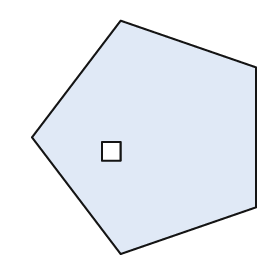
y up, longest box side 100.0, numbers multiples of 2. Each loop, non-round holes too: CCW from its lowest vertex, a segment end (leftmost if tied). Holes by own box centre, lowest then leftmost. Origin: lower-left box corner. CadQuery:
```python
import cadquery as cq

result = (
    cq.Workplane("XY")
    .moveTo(38.0, 0.0)
    .lineTo(96.0, 20.0)
    .lineTo(96.0, 80.0)
    .lineTo(38.0, 100.0)
    .lineTo(0.0, 50.0)
    .close()
    .moveTo(30.0, 40.0)
    .lineTo(38.0, 40.0)
    .lineTo(38.0, 48.0)
    .lineTo(30.0, 48.0)
    .close()
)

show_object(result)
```